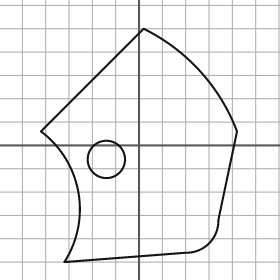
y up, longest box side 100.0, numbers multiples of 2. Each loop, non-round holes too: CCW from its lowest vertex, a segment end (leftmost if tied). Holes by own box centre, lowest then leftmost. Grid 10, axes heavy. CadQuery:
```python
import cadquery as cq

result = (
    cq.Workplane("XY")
    .moveTo(-32.0, -50.0)
    .lineTo(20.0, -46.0)
    .threePointArc((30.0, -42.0), (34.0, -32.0))
    .lineTo(42.0, 6.0)
    .threePointArc((26.0, 32.0), (2.0, 50.0))
    .lineTo(-42.0, 6.0)
    .threePointArc((-26.0, -20.0), (-32.0, -50.0))
    .close()
    .moveTo(-14.0, -6.0)
    .circle(8.0)
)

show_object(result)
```